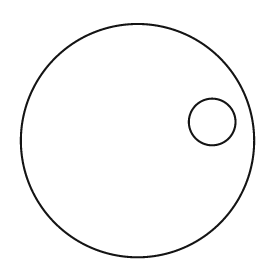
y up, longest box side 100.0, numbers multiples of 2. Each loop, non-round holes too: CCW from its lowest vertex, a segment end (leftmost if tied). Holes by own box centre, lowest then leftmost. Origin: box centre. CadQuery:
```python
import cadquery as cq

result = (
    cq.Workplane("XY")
    .moveTo(0.0, 0.0)
    .circle(50.0)
    .moveTo(32.0, 8.0)
    .circle(10.0)
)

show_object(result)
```